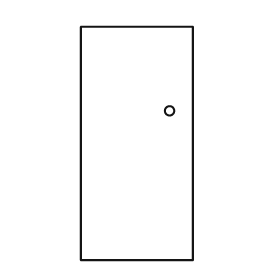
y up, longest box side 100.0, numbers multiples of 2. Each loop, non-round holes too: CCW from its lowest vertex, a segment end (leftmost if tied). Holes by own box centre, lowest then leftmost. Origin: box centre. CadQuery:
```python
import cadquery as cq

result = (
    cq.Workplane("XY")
    .moveTo(-24.0, -50.0)
    .lineTo(24.0, -50.0)
    .lineTo(24.0, 50.0)
    .lineTo(-24.0, 50.0)
    .close()
    .moveTo(14.0, 14.0)
    .circle(2.0)
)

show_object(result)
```